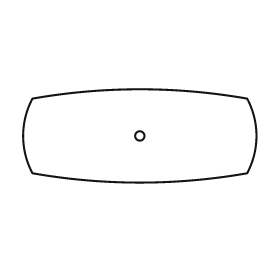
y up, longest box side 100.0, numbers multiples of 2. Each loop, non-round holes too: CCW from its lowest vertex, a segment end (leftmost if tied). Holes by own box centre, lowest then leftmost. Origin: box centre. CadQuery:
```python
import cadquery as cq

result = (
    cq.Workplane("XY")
    .moveTo(-46.0, -16.0)
    .threePointArc((0.0, -20.0), (46.0, -16.0))
    .threePointArc((50.0, 0.0), (46.0, 16.0))
    .threePointArc((0.0, 20.0), (-46.0, 16.0))
    .threePointArc((-50.0, 0.0), (-46.0, -16.0))
    .close()
    .moveTo(0.0, 0.0)
    .circle(2.0)
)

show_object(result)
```